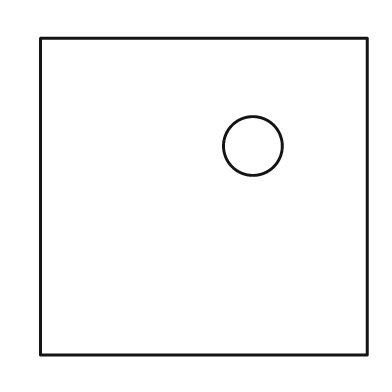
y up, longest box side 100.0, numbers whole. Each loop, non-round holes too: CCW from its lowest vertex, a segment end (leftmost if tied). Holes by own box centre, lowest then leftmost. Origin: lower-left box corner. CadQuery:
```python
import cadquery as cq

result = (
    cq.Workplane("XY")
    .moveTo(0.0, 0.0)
    .lineTo(100.0, 0.0)
    .lineTo(100.0, 97.0)
    .lineTo(0.0, 97.0)
    .close()
    .moveTo(65.0, 64.0)
    .circle(9.0)
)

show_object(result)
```